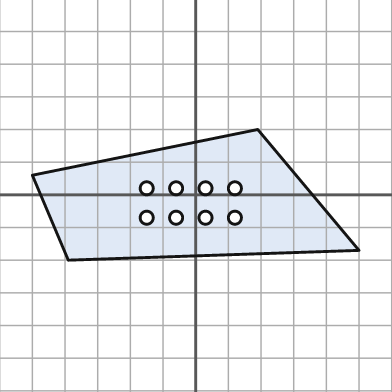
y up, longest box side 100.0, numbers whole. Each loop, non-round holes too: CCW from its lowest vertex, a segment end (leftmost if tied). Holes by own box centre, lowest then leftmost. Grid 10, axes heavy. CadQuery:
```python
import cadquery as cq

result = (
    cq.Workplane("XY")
    .moveTo(-39.0, -20.0)
    .lineTo(50.0, -17.0)
    .lineTo(19.0, 20.0)
    .lineTo(-50.0, 6.0)
    .close()
    .moveTo(-15.0, -7.0)
    .circle(2.0)
    .moveTo(-6.0, -7.0)
    .circle(2.0)
    .moveTo(3.0, -7.0)
    .circle(2.0)
    .moveTo(12.0, -7.0)
    .circle(2.0)
    .moveTo(-15.0, 2.0)
    .circle(2.0)
    .moveTo(-6.0, 2.0)
    .circle(2.0)
    .moveTo(3.0, 2.0)
    .circle(2.0)
    .moveTo(12.0, 2.0)
    .circle(2.0)
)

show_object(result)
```